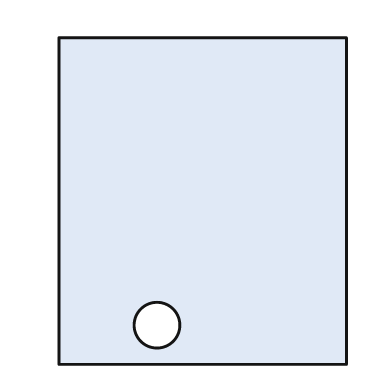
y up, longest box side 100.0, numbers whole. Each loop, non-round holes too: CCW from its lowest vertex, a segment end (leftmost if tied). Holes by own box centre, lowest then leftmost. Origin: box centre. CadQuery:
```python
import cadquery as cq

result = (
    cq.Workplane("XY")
    .moveTo(-44.0, -50.0)
    .lineTo(44.0, -50.0)
    .lineTo(44.0, 50.0)
    .lineTo(-44.0, 50.0)
    .close()
    .moveTo(-14.0, -38.0)
    .circle(7.0)
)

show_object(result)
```